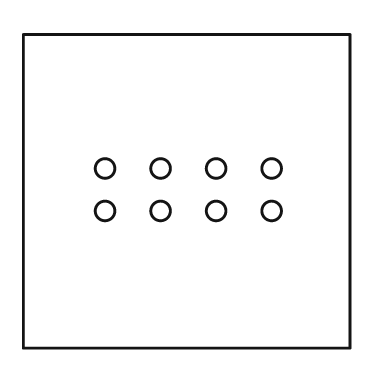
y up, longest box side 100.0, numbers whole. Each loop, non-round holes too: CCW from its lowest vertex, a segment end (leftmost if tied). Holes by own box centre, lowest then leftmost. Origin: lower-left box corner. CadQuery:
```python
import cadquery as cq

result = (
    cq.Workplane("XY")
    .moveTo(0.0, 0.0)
    .lineTo(100.0, 0.0)
    .lineTo(100.0, 96.0)
    .lineTo(0.0, 96.0)
    .close()
    .moveTo(25.0, 42.0)
    .circle(3.0)
    .moveTo(42.0, 42.0)
    .circle(3.0)
    .moveTo(59.0, 42.0)
    .circle(3.0)
    .moveTo(76.0, 42.0)
    .circle(3.0)
    .moveTo(25.0, 55.0)
    .circle(3.0)
    .moveTo(42.0, 55.0)
    .circle(3.0)
    .moveTo(59.0, 55.0)
    .circle(3.0)
    .moveTo(76.0, 55.0)
    .circle(3.0)
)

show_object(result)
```